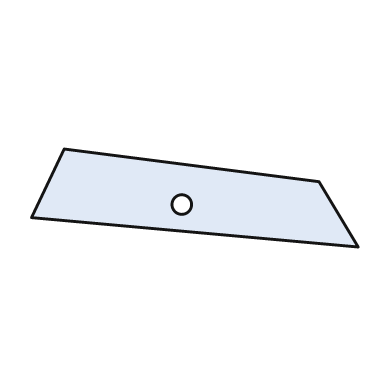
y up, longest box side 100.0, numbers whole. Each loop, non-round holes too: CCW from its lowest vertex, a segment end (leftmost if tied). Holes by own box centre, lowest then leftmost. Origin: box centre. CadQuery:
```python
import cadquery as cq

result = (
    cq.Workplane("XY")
    .moveTo(50.0, -15.0)
    .lineTo(38.0, 5.0)
    .lineTo(-40.0, 15.0)
    .lineTo(-50.0, -6.0)
    .close()
    .moveTo(-4.0, -2.0)
    .circle(3.0)
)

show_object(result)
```